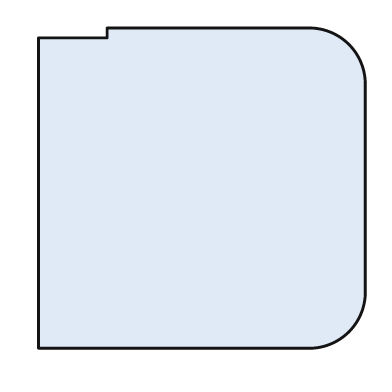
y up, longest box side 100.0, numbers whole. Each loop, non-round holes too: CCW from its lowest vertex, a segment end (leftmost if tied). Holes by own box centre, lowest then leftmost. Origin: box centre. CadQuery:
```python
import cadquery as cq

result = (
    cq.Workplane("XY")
    .moveTo(-50.0, -49.0)
    .lineTo(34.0, -49.0)
    .threePointArc((45.0, -44.0), (50.0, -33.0))
    .lineTo(50.0, 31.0)
    .threePointArc((45.0, 44.0), (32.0, 49.0))
    .lineTo(-29.0, 49.0)
    .lineTo(-29.0, 46.0)
    .lineTo(-50.0, 46.0)
    .close()
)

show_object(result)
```